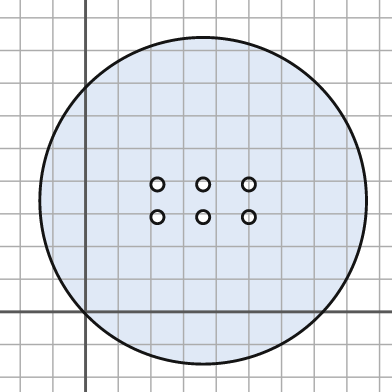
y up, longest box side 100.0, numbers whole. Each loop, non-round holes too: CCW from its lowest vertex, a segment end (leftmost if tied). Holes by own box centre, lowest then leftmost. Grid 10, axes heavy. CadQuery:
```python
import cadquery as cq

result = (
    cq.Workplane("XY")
    .moveTo(36.0, 34.0)
    .circle(50.0)
    .moveTo(22.0, 29.0)
    .circle(2.0)
    .moveTo(36.0, 29.0)
    .circle(2.0)
    .moveTo(50.0, 29.0)
    .circle(2.0)
    .moveTo(22.0, 39.0)
    .circle(2.0)
    .moveTo(36.0, 39.0)
    .circle(2.0)
    .moveTo(50.0, 39.0)
    .circle(2.0)
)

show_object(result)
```